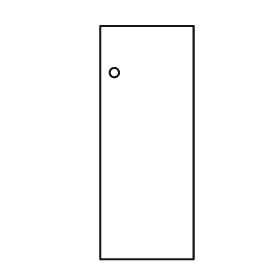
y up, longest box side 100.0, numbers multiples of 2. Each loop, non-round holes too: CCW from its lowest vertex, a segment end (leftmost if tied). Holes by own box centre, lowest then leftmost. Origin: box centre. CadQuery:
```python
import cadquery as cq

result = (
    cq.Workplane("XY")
    .moveTo(-20.0, -50.0)
    .lineTo(20.0, -50.0)
    .lineTo(20.0, 50.0)
    .lineTo(-20.0, 50.0)
    .close()
    .moveTo(-14.0, 30.0)
    .circle(2.0)
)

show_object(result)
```